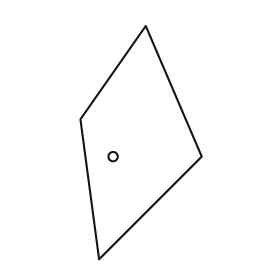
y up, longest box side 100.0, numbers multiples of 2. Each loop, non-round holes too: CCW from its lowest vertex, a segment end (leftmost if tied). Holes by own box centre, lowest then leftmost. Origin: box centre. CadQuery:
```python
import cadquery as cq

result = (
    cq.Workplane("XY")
    .moveTo(-18.0, -50.0)
    .lineTo(26.0, -6.0)
    .lineTo(2.0, 50.0)
    .lineTo(-26.0, 10.0)
    .close()
    .moveTo(-12.0, -6.0)
    .circle(2.0)
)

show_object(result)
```